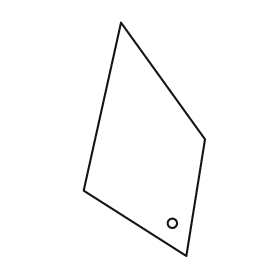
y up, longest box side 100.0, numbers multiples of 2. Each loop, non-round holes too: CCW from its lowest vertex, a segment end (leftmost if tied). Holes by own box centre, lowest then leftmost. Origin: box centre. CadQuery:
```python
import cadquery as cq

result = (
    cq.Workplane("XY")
    .moveTo(18.0, -50.0)
    .lineTo(26.0, 0.0)
    .lineTo(-10.0, 50.0)
    .lineTo(-26.0, -22.0)
    .close()
    .moveTo(12.0, -36.0)
    .circle(2.0)
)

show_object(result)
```